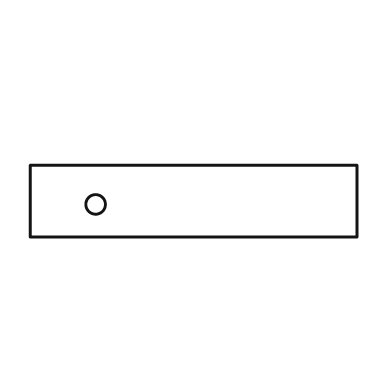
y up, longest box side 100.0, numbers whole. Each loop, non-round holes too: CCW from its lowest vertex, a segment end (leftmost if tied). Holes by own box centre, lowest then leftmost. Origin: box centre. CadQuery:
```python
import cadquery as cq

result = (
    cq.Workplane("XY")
    .moveTo(-50.0, -11.0)
    .lineTo(50.0, -11.0)
    .lineTo(50.0, 11.0)
    .lineTo(-50.0, 11.0)
    .close()
    .moveTo(-30.0, -1.0)
    .circle(3.0)
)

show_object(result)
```